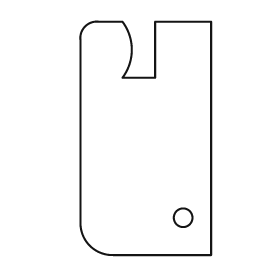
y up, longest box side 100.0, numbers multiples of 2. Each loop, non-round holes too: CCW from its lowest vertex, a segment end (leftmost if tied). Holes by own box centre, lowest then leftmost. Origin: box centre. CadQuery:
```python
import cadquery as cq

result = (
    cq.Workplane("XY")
    .moveTo(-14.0, -50.0)
    .lineTo(28.0, -50.0)
    .lineTo(28.0, 50.0)
    .lineTo(4.0, 50.0)
    .lineTo(4.0, 26.0)
    .lineTo(-10.0, 26.0)
    .threePointArc((-6.0, 38.0), (-10.0, 50.0))
    .lineTo(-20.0, 50.0)
    .threePointArc((-26.0, 48.0), (-28.0, 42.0))
    .lineTo(-28.0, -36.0)
    .threePointArc((-24.0, -46.0), (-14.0, -50.0))
    .close()
    .moveTo(16.0, -34.0)
    .circle(4.0)
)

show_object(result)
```